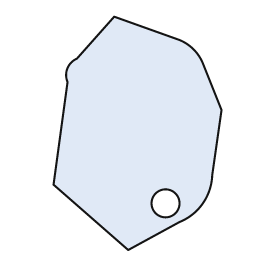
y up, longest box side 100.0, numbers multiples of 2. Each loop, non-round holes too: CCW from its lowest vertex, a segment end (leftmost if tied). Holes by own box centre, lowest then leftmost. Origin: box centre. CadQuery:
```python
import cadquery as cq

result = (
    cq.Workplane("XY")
    .moveTo(-4.0, -50.0)
    .lineTo(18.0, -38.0)
    .threePointArc((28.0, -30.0), (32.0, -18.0))
    .lineTo(36.0, 10.0)
    .lineTo(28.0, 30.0)
    .threePointArc((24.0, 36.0), (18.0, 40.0))
    .lineTo(-10.0, 50.0)
    .lineTo(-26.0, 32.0)
    .threePointArc((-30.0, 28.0), (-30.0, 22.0))
    .lineTo(-36.0, -22.0)
    .close()
    .moveTo(12.0, -30.0)
    .circle(6.0)
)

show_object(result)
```